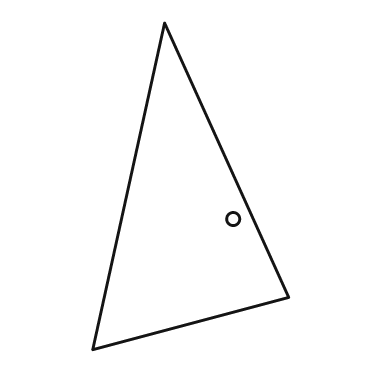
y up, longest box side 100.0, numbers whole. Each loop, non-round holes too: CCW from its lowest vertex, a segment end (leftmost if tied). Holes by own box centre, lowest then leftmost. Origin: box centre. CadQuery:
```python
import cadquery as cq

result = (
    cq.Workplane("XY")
    .moveTo(-30.0, -50.0)
    .lineTo(30.0, -34.0)
    .lineTo(-8.0, 50.0)
    .close()
    .moveTo(13.0, -10.0)
    .circle(2.0)
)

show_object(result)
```